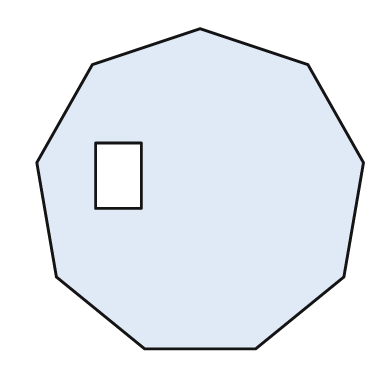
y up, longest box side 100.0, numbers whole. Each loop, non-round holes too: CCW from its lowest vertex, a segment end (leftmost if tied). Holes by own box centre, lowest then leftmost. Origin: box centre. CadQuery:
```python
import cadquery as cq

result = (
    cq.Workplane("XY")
    .moveTo(-17.0, -49.0)
    .lineTo(17.0, -49.0)
    .lineTo(44.0, -27.0)
    .lineTo(50.0, 8.0)
    .lineTo(33.0, 38.0)
    .lineTo(0.0, 49.0)
    .lineTo(-33.0, 38.0)
    .lineTo(-50.0, 8.0)
    .lineTo(-44.0, -27.0)
    .close()
    .moveTo(-32.0, -6.0)
    .lineTo(-18.0, -6.0)
    .lineTo(-18.0, 14.0)
    .lineTo(-32.0, 14.0)
    .close()
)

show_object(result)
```